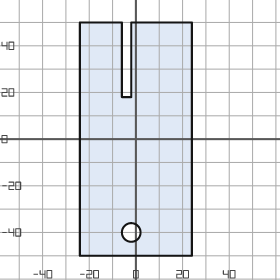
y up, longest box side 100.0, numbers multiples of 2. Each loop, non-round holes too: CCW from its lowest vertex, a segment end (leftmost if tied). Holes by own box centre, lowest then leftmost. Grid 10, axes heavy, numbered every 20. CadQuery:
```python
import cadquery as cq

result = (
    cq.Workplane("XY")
    .moveTo(-24.0, -50.0)
    .lineTo(24.0, -50.0)
    .lineTo(24.0, 50.0)
    .lineTo(-2.0, 50.0)
    .lineTo(-2.0, 18.0)
    .lineTo(-6.0, 18.0)
    .lineTo(-6.0, 50.0)
    .lineTo(-24.0, 50.0)
    .close()
    .moveTo(-2.0, -40.0)
    .circle(4.0)
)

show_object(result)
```